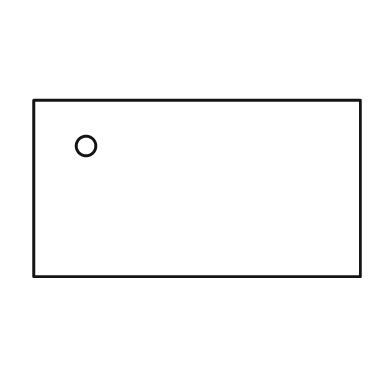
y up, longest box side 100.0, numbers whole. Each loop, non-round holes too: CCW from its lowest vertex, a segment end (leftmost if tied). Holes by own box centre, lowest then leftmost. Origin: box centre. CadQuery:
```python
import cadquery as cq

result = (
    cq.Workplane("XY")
    .moveTo(-50.0, -27.0)
    .lineTo(50.0, -27.0)
    .lineTo(50.0, 27.0)
    .lineTo(-50.0, 27.0)
    .close()
    .moveTo(-34.0, 13.0)
    .circle(3.0)
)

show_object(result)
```